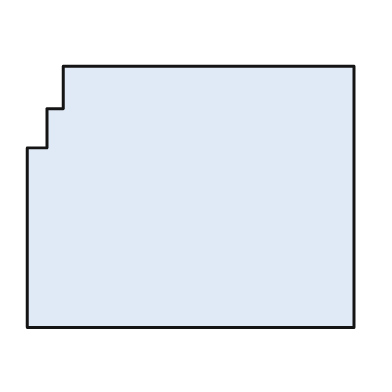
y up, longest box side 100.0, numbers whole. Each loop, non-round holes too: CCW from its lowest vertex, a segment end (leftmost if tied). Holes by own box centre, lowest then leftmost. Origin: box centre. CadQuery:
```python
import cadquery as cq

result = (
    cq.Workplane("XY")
    .moveTo(-50.0, -40.0)
    .lineTo(50.0, -40.0)
    .lineTo(50.0, 40.0)
    .lineTo(-39.0, 40.0)
    .lineTo(-39.0, 27.0)
    .lineTo(-44.0, 27.0)
    .lineTo(-44.0, 15.0)
    .lineTo(-50.0, 15.0)
    .close()
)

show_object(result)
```